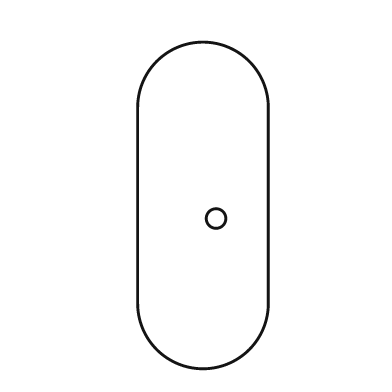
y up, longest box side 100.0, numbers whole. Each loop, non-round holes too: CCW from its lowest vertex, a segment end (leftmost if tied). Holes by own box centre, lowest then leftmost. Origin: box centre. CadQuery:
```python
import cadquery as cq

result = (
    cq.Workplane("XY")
    .moveTo(-20.0, -30.0)
    .threePointArc((0.0, -50.0), (20.0, -30.0))
    .lineTo(20.0, 30.0)
    .threePointArc((0.0, 50.0), (-20.0, 30.0))
    .close()
    .moveTo(4.0, -4.0)
    .circle(3.0)
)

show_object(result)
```